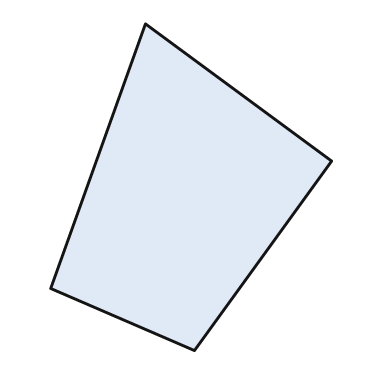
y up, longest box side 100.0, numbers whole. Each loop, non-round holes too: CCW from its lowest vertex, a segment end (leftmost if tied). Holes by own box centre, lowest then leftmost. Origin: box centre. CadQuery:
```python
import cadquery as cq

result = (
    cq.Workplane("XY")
    .moveTo(1.0, -50.0)
    .lineTo(43.0, 8.0)
    .lineTo(-14.0, 50.0)
    .lineTo(-43.0, -31.0)
    .close()
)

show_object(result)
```